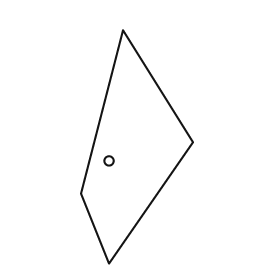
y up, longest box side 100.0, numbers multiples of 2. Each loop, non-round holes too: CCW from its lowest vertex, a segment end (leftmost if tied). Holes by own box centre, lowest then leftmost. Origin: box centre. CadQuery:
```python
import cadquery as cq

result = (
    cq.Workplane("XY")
    .moveTo(-12.0, -50.0)
    .lineTo(24.0, 2.0)
    .lineTo(-6.0, 50.0)
    .lineTo(-24.0, -20.0)
    .close()
    .moveTo(-12.0, -6.0)
    .circle(2.0)
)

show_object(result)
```